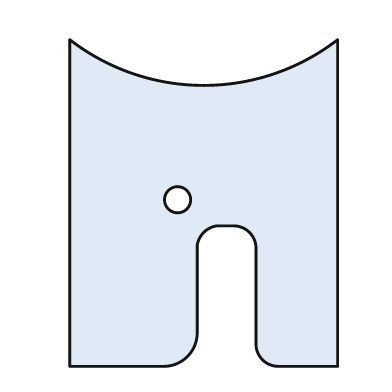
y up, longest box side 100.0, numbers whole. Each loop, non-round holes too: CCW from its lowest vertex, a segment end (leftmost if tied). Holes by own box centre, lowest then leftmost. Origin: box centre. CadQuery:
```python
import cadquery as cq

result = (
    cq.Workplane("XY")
    .moveTo(-41.0, -50.0)
    .lineTo(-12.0, -50.0)
    .threePointArc((-5.0, -47.0), (-2.0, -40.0))
    .lineTo(-2.0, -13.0)
    .threePointArc((0.0, -9.0), (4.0, -7.0))
    .lineTo(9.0, -7.0)
    .threePointArc((14.0, -9.0), (16.0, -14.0))
    .lineTo(16.0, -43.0)
    .threePointArc((18.0, -48.0), (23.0, -50.0))
    .lineTo(41.0, -50.0)
    .lineTo(41.0, 50.0)
    .threePointArc((0.0, 36.0), (-41.0, 50.0))
    .close()
    .moveTo(-8.0, 1.0)
    .circle(4.0)
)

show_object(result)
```